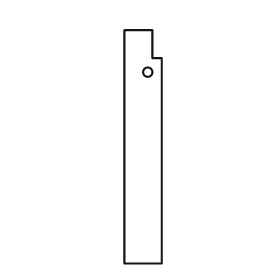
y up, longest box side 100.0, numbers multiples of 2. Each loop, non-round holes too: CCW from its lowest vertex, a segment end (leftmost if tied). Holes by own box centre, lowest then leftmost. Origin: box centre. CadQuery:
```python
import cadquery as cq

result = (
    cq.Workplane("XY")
    .moveTo(-8.0, -50.0)
    .lineTo(8.0, -50.0)
    .lineTo(8.0, 38.0)
    .lineTo(4.0, 38.0)
    .lineTo(4.0, 50.0)
    .lineTo(-8.0, 50.0)
    .close()
    .moveTo(2.0, 32.0)
    .circle(2.0)
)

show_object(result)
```